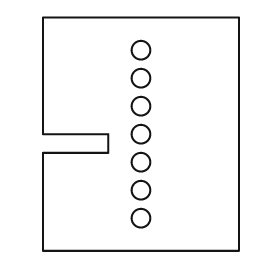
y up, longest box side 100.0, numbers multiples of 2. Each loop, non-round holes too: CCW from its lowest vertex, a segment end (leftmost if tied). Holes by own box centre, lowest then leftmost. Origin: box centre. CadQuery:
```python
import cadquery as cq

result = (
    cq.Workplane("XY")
    .moveTo(-42.0, -50.0)
    .lineTo(42.0, -50.0)
    .lineTo(42.0, 50.0)
    .lineTo(-42.0, 50.0)
    .lineTo(-42.0, 0.0)
    .lineTo(-14.0, 0.0)
    .lineTo(-14.0, -8.0)
    .lineTo(-42.0, -8.0)
    .close()
    .moveTo(0.0, -36.0)
    .circle(4.0)
    .moveTo(0.0, -24.0)
    .circle(4.0)
    .moveTo(0.0, -12.0)
    .circle(4.0)
    .moveTo(0.0, 0.0)
    .circle(4.0)
    .moveTo(0.0, 12.0)
    .circle(4.0)
    .moveTo(0.0, 24.0)
    .circle(4.0)
    .moveTo(0.0, 36.0)
    .circle(4.0)
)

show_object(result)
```